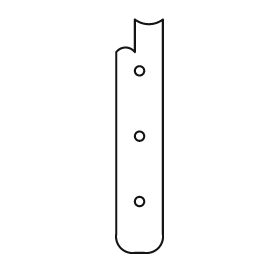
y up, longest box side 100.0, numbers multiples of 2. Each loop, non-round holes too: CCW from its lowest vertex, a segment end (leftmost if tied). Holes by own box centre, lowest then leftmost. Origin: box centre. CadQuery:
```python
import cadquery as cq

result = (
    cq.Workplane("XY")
    .moveTo(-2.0, -50.0)
    .lineTo(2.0, -50.0)
    .threePointArc((8.0, -48.0), (10.0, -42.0))
    .lineTo(10.0, 50.0)
    .threePointArc((4.0, 48.0), (-2.0, 50.0))
    .lineTo(-2.0, 36.0)
    .threePointArc((-6.0, 38.0), (-10.0, 36.0))
    .lineTo(-10.0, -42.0)
    .threePointArc((-8.0, -48.0), (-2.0, -50.0))
    .close()
    .moveTo(0.0, -28.0)
    .circle(2.0)
    .moveTo(0.0, 0.0)
    .circle(2.0)
    .moveTo(0.0, 28.0)
    .circle(2.0)
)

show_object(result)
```